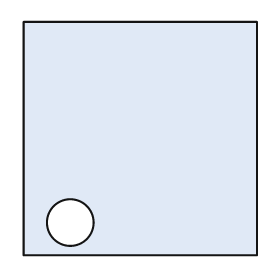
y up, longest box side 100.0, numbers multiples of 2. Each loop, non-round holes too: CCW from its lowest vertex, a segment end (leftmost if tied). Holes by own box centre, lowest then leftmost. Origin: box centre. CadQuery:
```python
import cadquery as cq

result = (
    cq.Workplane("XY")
    .moveTo(-50.0, -50.0)
    .lineTo(50.0, -50.0)
    .lineTo(50.0, 50.0)
    .lineTo(-50.0, 50.0)
    .close()
    .moveTo(-30.0, -36.0)
    .circle(10.0)
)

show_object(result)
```